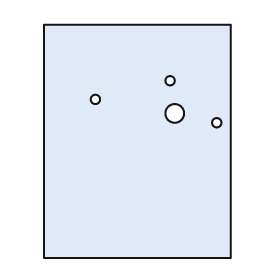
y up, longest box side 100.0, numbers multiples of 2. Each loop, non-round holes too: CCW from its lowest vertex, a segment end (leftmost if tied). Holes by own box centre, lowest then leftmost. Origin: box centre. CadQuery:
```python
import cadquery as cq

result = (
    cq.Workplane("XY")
    .moveTo(-40.0, -50.0)
    .lineTo(40.0, -50.0)
    .lineTo(40.0, 50.0)
    .lineTo(-40.0, 50.0)
    .close()
    .moveTo(34.0, 8.0)
    .circle(2.0)
    .moveTo(16.0, 12.0)
    .circle(4.0)
    .moveTo(-18.0, 18.0)
    .circle(2.0)
    .moveTo(14.0, 26.0)
    .circle(2.0)
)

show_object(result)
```